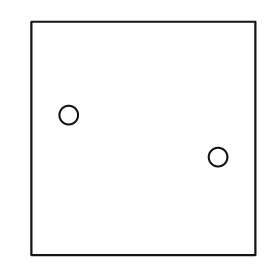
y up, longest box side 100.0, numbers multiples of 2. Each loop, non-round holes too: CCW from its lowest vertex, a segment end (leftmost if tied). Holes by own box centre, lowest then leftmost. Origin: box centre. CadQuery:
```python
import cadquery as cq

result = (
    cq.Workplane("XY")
    .moveTo(-48.0, -50.0)
    .lineTo(48.0, -50.0)
    .lineTo(48.0, 50.0)
    .lineTo(-48.0, 50.0)
    .close()
    .moveTo(32.0, -8.0)
    .circle(4.0)
    .moveTo(-32.0, 10.0)
    .circle(4.0)
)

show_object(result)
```